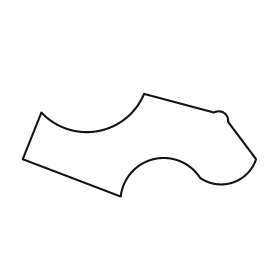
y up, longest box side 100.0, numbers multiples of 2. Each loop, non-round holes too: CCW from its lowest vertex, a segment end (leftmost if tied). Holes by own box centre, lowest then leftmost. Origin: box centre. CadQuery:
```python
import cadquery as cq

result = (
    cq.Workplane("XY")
    .moveTo(-8.0, -22.0)
    .threePointArc((6.0, -6.0), (26.0, -14.0))
    .threePointArc((40.0, -16.0), (50.0, -6.0))
    .lineTo(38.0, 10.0)
    .threePointArc((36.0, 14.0), (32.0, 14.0))
    .lineTo(2.0, 22.0)
    .threePointArc((-18.0, 6.0), (-42.0, 14.0))
    .lineTo(-50.0, -6.0)
    .close()
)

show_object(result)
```